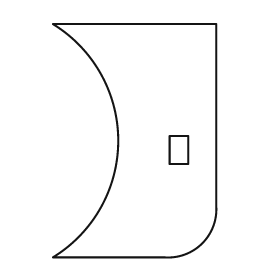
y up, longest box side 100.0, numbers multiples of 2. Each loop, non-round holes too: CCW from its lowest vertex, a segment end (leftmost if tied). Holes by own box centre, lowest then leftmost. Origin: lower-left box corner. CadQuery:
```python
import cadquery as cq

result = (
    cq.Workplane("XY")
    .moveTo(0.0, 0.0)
    .lineTo(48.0, 0.0)
    .threePointArc((64.0, 6.0), (70.0, 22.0))
    .lineTo(70.0, 100.0)
    .lineTo(0.0, 100.0)
    .threePointArc((28.0, 50.0), (0.0, 0.0))
    .close()
    .moveTo(50.0, 40.0)
    .lineTo(58.0, 40.0)
    .lineTo(58.0, 52.0)
    .lineTo(50.0, 52.0)
    .close()
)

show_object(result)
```